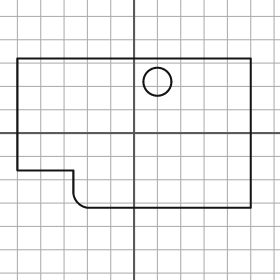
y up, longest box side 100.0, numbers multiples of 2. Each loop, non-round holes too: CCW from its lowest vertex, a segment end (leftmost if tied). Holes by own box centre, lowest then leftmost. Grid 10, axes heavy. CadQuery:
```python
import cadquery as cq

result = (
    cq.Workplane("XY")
    .moveTo(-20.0, -32.0)
    .lineTo(50.0, -32.0)
    .lineTo(50.0, 32.0)
    .lineTo(-50.0, 32.0)
    .lineTo(-50.0, -16.0)
    .lineTo(-26.0, -16.0)
    .lineTo(-26.0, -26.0)
    .threePointArc((-24.0, -30.0), (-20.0, -32.0))
    .close()
    .moveTo(10.0, 22.0)
    .circle(6.0)
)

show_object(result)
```